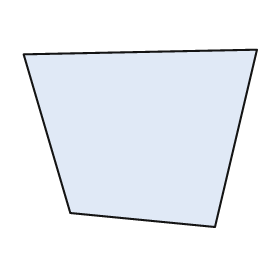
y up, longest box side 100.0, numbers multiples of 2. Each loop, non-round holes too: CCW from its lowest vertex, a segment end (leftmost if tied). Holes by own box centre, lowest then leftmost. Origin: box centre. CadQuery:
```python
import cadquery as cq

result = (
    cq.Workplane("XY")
    .moveTo(32.0, -38.0)
    .lineTo(50.0, 38.0)
    .lineTo(-50.0, 36.0)
    .lineTo(-30.0, -32.0)
    .close()
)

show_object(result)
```